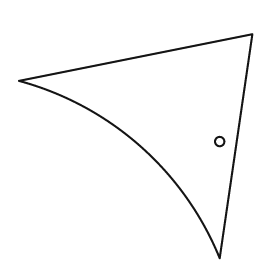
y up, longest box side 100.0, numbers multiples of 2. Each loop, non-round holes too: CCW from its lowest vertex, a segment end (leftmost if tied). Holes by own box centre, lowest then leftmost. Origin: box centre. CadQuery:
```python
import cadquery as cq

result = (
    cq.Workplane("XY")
    .moveTo(36.0, -48.0)
    .lineTo(50.0, 48.0)
    .lineTo(-50.0, 28.0)
    .threePointArc((2.0, 0.0), (36.0, -48.0))
    .close()
    .moveTo(36.0, 2.0)
    .circle(2.0)
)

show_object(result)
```